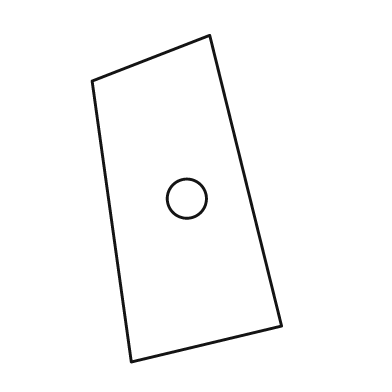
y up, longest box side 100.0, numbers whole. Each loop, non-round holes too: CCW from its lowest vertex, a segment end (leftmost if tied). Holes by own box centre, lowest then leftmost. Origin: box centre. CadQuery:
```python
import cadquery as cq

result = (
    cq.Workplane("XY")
    .moveTo(-17.0, -50.0)
    .lineTo(29.0, -39.0)
    .lineTo(7.0, 50.0)
    .lineTo(-29.0, 36.0)
    .close()
    .moveTo(0.0, 0.0)
    .circle(6.0)
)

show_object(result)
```